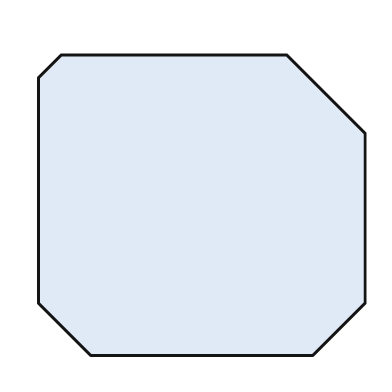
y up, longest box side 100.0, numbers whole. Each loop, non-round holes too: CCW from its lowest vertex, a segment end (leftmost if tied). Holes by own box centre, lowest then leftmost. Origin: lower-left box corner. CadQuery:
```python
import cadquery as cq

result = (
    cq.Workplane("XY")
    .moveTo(16.0, 0.0)
    .lineTo(84.0, 0.0)
    .lineTo(100.0, 16.0)
    .lineTo(100.0, 68.0)
    .lineTo(76.0, 92.0)
    .lineTo(7.0, 92.0)
    .lineTo(0.0, 85.0)
    .lineTo(0.0, 16.0)
    .close()
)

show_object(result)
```